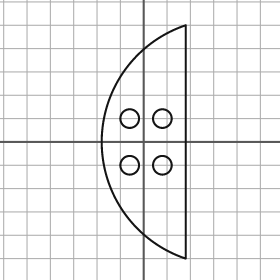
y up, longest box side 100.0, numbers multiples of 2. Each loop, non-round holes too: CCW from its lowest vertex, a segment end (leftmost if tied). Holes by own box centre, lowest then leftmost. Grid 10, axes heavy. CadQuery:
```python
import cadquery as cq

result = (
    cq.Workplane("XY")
    .moveTo(18.0, -50.0)
    .lineTo(18.0, 50.0)
    .threePointArc((-18.0, 0.0), (18.0, -50.0))
    .close()
    .moveTo(-6.0, -10.0)
    .circle(4.0)
    .moveTo(8.0, -10.0)
    .circle(4.0)
    .moveTo(-6.0, 10.0)
    .circle(4.0)
    .moveTo(8.0, 10.0)
    .circle(4.0)
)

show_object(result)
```